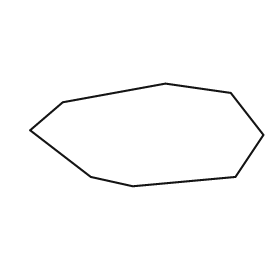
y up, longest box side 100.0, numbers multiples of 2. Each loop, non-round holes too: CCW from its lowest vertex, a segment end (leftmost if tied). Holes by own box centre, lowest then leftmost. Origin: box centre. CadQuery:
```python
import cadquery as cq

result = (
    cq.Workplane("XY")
    .moveTo(-6.0, -22.0)
    .lineTo(38.0, -18.0)
    .lineTo(50.0, 0.0)
    .lineTo(36.0, 18.0)
    .lineTo(8.0, 22.0)
    .lineTo(-36.0, 14.0)
    .lineTo(-50.0, 2.0)
    .lineTo(-24.0, -18.0)
    .close()
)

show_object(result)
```